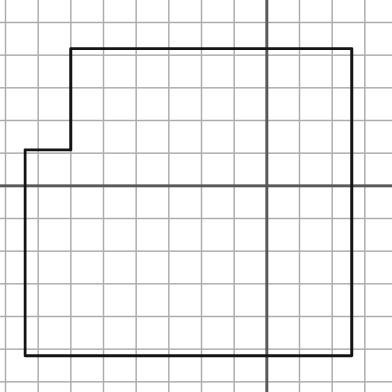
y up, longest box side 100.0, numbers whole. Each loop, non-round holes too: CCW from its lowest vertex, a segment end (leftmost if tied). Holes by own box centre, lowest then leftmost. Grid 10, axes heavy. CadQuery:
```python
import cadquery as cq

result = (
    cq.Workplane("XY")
    .moveTo(-74.0, -52.0)
    .lineTo(26.0, -52.0)
    .lineTo(26.0, 42.0)
    .lineTo(-60.0, 42.0)
    .lineTo(-60.0, 11.0)
    .lineTo(-74.0, 11.0)
    .close()
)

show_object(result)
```